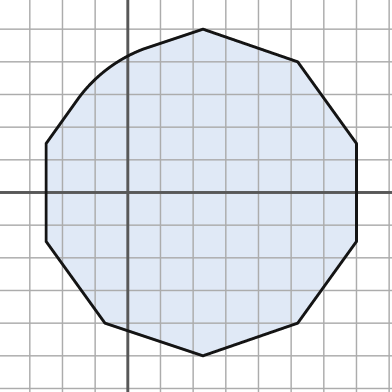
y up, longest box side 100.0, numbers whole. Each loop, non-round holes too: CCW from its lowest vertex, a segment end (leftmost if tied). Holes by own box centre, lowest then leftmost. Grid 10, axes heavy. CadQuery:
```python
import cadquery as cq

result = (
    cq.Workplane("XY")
    .moveTo(23.0, -50.0)
    .lineTo(52.0, -40.0)
    .lineTo(70.0, -15.0)
    .lineTo(70.0, 15.0)
    .lineTo(52.0, 40.0)
    .lineTo(23.0, 50.0)
    .lineTo(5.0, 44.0)
    .threePointArc((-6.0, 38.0), (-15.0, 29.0))
    .lineTo(-25.0, 15.0)
    .lineTo(-25.0, -15.0)
    .lineTo(-7.0, -40.0)
    .close()
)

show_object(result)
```